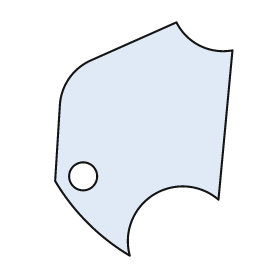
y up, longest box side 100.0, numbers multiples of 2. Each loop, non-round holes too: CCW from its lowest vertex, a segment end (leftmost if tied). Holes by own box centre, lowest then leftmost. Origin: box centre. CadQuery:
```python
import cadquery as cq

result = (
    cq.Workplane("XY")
    .moveTo(-6.0, -50.0)
    .threePointArc((4.0, -24.0), (32.0, -26.0))
    .lineTo(38.0, 38.0)
    .threePointArc((24.0, 40.0), (14.0, 50.0))
    .lineTo(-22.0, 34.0)
    .threePointArc((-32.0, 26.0), (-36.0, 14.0))
    .lineTo(-38.0, -18.0)
    .threePointArc((-24.0, -36.0), (-6.0, -50.0))
    .close()
    .moveTo(-26.0, -16.0)
    .circle(6.0)
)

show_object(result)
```